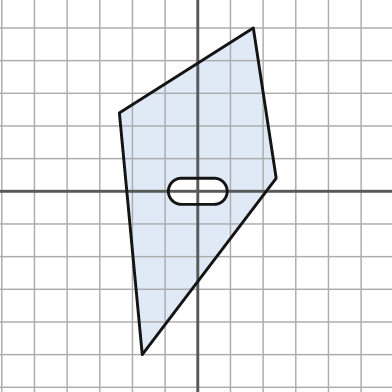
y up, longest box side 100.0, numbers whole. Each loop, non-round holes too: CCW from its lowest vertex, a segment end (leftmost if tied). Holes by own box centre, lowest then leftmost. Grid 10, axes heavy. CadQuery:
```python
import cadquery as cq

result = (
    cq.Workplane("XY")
    .moveTo(-17.0, -50.0)
    .lineTo(24.0, 4.0)
    .lineTo(17.0, 50.0)
    .lineTo(-24.0, 24.0)
    .close()
    .moveTo(-5.0, -4.0)
    .lineTo(5.0, -4.0)
    .threePointArc((9.0, 0.0), (5.0, 4.0))
    .lineTo(-5.0, 4.0)
    .threePointArc((-9.0, 0.0), (-5.0, -4.0))
    .close()
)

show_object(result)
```